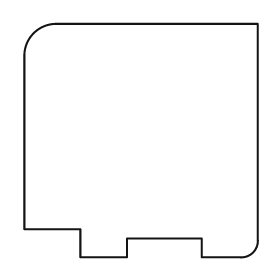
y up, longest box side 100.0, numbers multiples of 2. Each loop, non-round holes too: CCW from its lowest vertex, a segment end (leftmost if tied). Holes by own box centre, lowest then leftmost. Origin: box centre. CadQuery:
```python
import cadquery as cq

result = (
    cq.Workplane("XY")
    .moveTo(-26.0, -50.0)
    .lineTo(-6.0, -50.0)
    .lineTo(-6.0, -42.0)
    .lineTo(26.0, -42.0)
    .lineTo(26.0, -50.0)
    .lineTo(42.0, -50.0)
    .threePointArc((48.0, -48.0), (50.0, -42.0))
    .lineTo(50.0, 50.0)
    .lineTo(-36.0, 50.0)
    .threePointArc((-46.0, 46.0), (-50.0, 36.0))
    .lineTo(-50.0, -38.0)
    .lineTo(-26.0, -38.0)
    .close()
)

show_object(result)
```